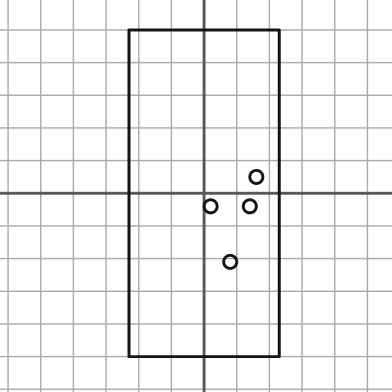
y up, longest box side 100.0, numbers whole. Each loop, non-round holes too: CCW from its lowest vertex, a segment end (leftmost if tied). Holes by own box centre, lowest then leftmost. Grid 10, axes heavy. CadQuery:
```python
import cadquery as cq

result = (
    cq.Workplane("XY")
    .moveTo(-23.0, -50.0)
    .lineTo(23.0, -50.0)
    .lineTo(23.0, 50.0)
    .lineTo(-23.0, 50.0)
    .close()
    .moveTo(8.0, -21.0)
    .circle(2.0)
    .moveTo(2.0, -4.0)
    .circle(2.0)
    .moveTo(14.0, -4.0)
    .circle(2.0)
    .moveTo(16.0, 5.0)
    .circle(2.0)
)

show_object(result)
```